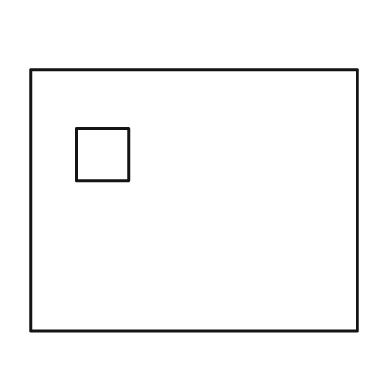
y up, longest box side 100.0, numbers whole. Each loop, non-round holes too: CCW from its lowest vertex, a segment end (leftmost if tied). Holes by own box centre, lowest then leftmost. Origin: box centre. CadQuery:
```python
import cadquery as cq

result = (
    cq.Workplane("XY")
    .moveTo(-50.0, -40.0)
    .lineTo(50.0, -40.0)
    .lineTo(50.0, 40.0)
    .lineTo(-50.0, 40.0)
    .close()
    .moveTo(-36.0, 6.0)
    .lineTo(-20.0, 6.0)
    .lineTo(-20.0, 22.0)
    .lineTo(-36.0, 22.0)
    .close()
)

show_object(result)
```